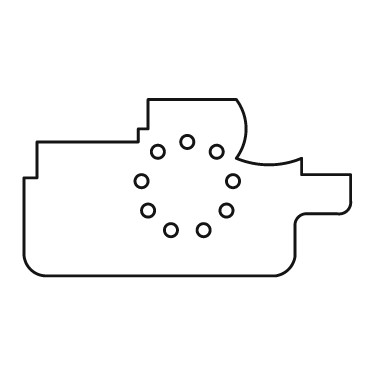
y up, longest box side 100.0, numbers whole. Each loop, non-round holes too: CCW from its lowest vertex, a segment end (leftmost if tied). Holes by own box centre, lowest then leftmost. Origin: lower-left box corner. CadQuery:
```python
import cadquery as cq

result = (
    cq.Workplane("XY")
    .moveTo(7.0, 0.0)
    .lineTo(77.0, 0.0)
    .threePointArc((81.0, 2.0), (83.0, 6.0))
    .lineTo(83.0, 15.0)
    .threePointArc((84.0, 18.0), (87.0, 19.0))
    .lineTo(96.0, 19.0)
    .threePointArc((99.0, 20.0), (100.0, 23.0))
    .lineTo(100.0, 31.0)
    .lineTo(85.0, 31.0)
    .lineTo(85.0, 36.0)
    .threePointArc((75.0, 34.0), (65.0, 36.0))
    .threePointArc((68.0, 45.0), (65.0, 54.0))
    .lineTo(38.0, 54.0)
    .lineTo(38.0, 45.0)
    .lineTo(35.0, 45.0)
    .lineTo(35.0, 41.0)
    .lineTo(4.0, 41.0)
    .lineTo(4.0, 30.0)
    .lineTo(0.0, 30.0)
    .lineTo(0.0, 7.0)
    .threePointArc((2.0, 2.0), (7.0, 0.0))
    .close()
    .moveTo(45.0, 14.0)
    .circle(2.0)
    .moveTo(55.0, 14.0)
    .circle(2.0)
    .moveTo(38.0, 20.0)
    .circle(2.0)
    .moveTo(62.0, 20.0)
    .circle(2.0)
    .moveTo(36.0, 29.0)
    .circle(2.0)
    .moveTo(64.0, 29.0)
    .circle(2.0)
    .moveTo(41.0, 38.0)
    .circle(2.0)
    .moveTo(59.0, 38.0)
    .circle(2.0)
    .moveTo(50.0, 41.0)
    .circle(2.0)
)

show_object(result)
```